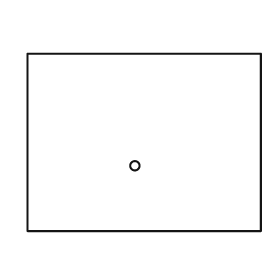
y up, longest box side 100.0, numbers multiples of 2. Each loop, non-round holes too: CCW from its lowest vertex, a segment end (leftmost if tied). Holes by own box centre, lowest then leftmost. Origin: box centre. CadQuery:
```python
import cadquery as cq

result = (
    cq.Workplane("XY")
    .moveTo(-50.0, -38.0)
    .lineTo(50.0, -38.0)
    .lineTo(50.0, 38.0)
    .lineTo(-50.0, 38.0)
    .close()
    .moveTo(-4.0, -10.0)
    .circle(2.0)
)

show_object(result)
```